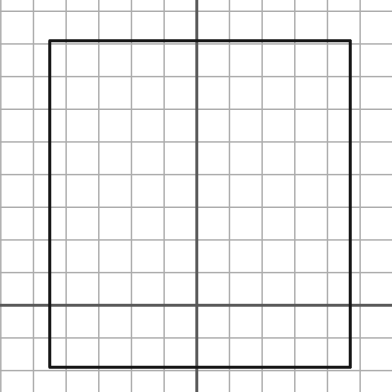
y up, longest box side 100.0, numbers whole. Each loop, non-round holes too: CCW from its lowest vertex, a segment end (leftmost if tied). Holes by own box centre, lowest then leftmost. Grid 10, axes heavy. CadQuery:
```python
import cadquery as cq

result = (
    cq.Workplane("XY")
    .moveTo(-45.0, -19.0)
    .lineTo(47.0, -19.0)
    .lineTo(47.0, 81.0)
    .lineTo(-45.0, 81.0)
    .close()
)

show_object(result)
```